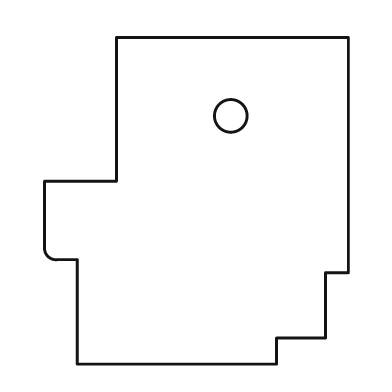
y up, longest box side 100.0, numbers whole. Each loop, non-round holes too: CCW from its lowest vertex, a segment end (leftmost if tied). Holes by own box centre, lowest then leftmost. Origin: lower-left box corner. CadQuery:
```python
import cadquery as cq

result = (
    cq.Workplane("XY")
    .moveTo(10.0, 0.0)
    .lineTo(71.0, 0.0)
    .lineTo(71.0, 8.0)
    .lineTo(86.0, 8.0)
    .lineTo(86.0, 28.0)
    .lineTo(93.0, 28.0)
    .lineTo(93.0, 100.0)
    .lineTo(22.0, 100.0)
    .lineTo(22.0, 56.0)
    .lineTo(0.0, 56.0)
    .lineTo(0.0, 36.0)
    .threePointArc((1.0, 33.0), (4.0, 32.0))
    .lineTo(10.0, 32.0)
    .close()
    .moveTo(57.0, 76.0)
    .circle(5.0)
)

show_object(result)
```